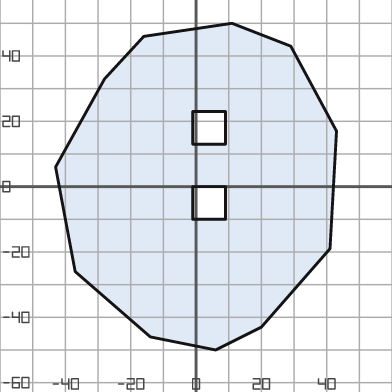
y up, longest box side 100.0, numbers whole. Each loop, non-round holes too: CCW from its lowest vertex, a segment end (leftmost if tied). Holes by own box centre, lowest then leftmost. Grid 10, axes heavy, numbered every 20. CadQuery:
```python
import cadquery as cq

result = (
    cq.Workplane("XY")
    .moveTo(6.0, -50.0)
    .lineTo(20.0, -43.0)
    .lineTo(41.0, -19.0)
    .lineTo(43.0, 17.0)
    .lineTo(29.0, 43.0)
    .lineTo(11.0, 50.0)
    .lineTo(-16.0, 46.0)
    .lineTo(-28.0, 33.0)
    .lineTo(-43.0, 6.0)
    .lineTo(-37.0, -26.0)
    .lineTo(-14.0, -46.0)
    .close()
    .moveTo(-1.0, -10.0)
    .lineTo(9.0, -10.0)
    .lineTo(9.0, 0.0)
    .lineTo(-1.0, 0.0)
    .close()
    .moveTo(-1.0, 13.0)
    .lineTo(9.0, 13.0)
    .lineTo(9.0, 23.0)
    .lineTo(-1.0, 23.0)
    .close()
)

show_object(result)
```